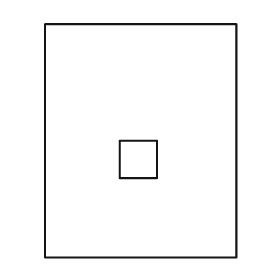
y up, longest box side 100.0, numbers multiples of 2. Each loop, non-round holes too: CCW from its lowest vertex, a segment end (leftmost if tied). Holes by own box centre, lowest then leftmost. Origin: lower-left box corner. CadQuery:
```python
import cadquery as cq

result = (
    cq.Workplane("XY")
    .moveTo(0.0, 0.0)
    .lineTo(82.0, 0.0)
    .lineTo(82.0, 100.0)
    .lineTo(0.0, 100.0)
    .close()
    .moveTo(32.0, 34.0)
    .lineTo(48.0, 34.0)
    .lineTo(48.0, 50.0)
    .lineTo(32.0, 50.0)
    .close()
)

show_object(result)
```